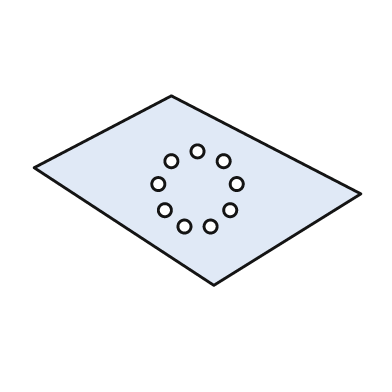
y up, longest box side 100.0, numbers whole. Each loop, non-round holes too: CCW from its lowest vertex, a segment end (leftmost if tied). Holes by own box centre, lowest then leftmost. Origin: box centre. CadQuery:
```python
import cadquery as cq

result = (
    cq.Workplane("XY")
    .moveTo(5.0, -29.0)
    .lineTo(50.0, -1.0)
    .lineTo(-8.0, 29.0)
    .lineTo(-50.0, 7.0)
    .close()
    .moveTo(-4.0, -11.0)
    .circle(2.0)
    .moveTo(4.0, -11.0)
    .circle(2.0)
    .moveTo(-10.0, -6.0)
    .circle(2.0)
    .moveTo(10.0, -6.0)
    .circle(2.0)
    .moveTo(-12.0, 2.0)
    .circle(2.0)
    .moveTo(12.0, 2.0)
    .circle(2.0)
    .moveTo(-8.0, 9.0)
    .circle(2.0)
    .moveTo(8.0, 9.0)
    .circle(2.0)
    .moveTo(0.0, 12.0)
    .circle(2.0)
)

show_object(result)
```